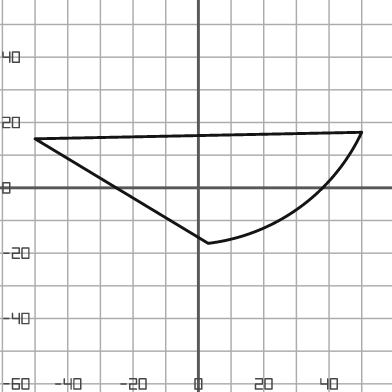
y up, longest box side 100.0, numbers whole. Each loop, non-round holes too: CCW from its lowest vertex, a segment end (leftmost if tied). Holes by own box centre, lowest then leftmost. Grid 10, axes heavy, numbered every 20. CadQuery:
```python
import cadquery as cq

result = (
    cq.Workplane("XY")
    .moveTo(3.0, -17.0)
    .threePointArc((31.0, -6.0), (50.0, 17.0))
    .lineTo(-50.0, 15.0)
    .close()
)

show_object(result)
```